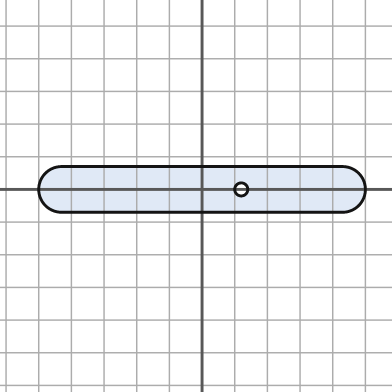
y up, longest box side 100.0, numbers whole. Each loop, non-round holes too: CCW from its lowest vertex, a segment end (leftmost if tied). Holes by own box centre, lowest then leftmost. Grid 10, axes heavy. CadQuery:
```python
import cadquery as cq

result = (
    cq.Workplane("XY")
    .moveTo(-43.0, -7.0)
    .lineTo(43.0, -7.0)
    .threePointArc((50.0, 0.0), (43.0, 7.0))
    .lineTo(-43.0, 7.0)
    .threePointArc((-50.0, 0.0), (-43.0, -7.0))
    .close()
    .moveTo(12.0, 0.0)
    .circle(2.0)
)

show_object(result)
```